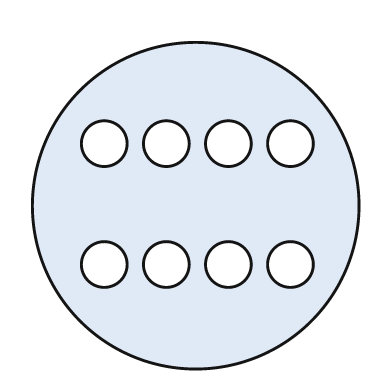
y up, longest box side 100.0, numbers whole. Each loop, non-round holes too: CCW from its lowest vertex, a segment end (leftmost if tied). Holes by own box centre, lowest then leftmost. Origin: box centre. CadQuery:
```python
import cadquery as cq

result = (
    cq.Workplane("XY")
    .moveTo(0.0, 0.0)
    .circle(50.0)
    .moveTo(-28.0, -18.0)
    .circle(7.0)
    .moveTo(-9.0, -18.0)
    .circle(7.0)
    .moveTo(10.0, -18.0)
    .circle(7.0)
    .moveTo(29.0, -18.0)
    .circle(7.0)
    .moveTo(-28.0, 19.0)
    .circle(7.0)
    .moveTo(-9.0, 19.0)
    .circle(7.0)
    .moveTo(10.0, 19.0)
    .circle(7.0)
    .moveTo(29.0, 19.0)
    .circle(7.0)
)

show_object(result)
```